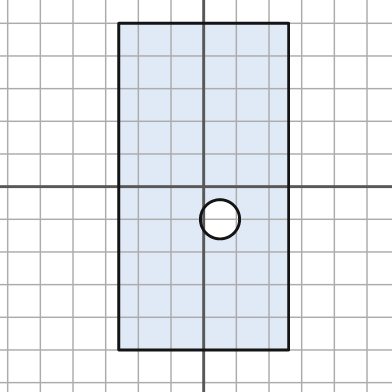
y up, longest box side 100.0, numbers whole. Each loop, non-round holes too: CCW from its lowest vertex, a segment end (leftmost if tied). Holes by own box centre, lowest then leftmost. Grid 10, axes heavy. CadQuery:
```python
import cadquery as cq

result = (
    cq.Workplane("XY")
    .moveTo(-26.0, -50.0)
    .lineTo(26.0, -50.0)
    .lineTo(26.0, 50.0)
    .lineTo(-26.0, 50.0)
    .close()
    .moveTo(5.0, -10.0)
    .circle(6.0)
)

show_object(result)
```